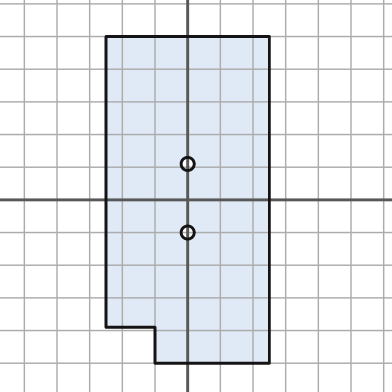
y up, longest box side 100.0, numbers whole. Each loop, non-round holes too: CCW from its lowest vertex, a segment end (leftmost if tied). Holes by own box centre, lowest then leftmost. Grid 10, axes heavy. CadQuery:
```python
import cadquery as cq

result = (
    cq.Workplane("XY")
    .moveTo(-10.0, -50.0)
    .lineTo(25.0, -50.0)
    .lineTo(25.0, 50.0)
    .lineTo(-25.0, 50.0)
    .lineTo(-25.0, -39.0)
    .lineTo(-10.0, -39.0)
    .close()
    .moveTo(0.0, -10.0)
    .circle(2.0)
    .moveTo(0.0, 11.0)
    .circle(2.0)
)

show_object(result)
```